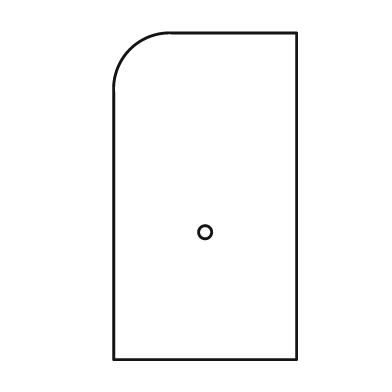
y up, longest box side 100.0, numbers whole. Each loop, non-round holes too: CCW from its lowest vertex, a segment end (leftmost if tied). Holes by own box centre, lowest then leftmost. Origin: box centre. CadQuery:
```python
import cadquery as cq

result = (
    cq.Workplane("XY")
    .moveTo(-28.0, -50.0)
    .lineTo(28.0, -50.0)
    .lineTo(28.0, 50.0)
    .lineTo(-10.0, 50.0)
    .threePointArc((-23.0, 45.0), (-28.0, 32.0))
    .close()
    .moveTo(0.0, -11.0)
    .circle(2.0)
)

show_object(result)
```